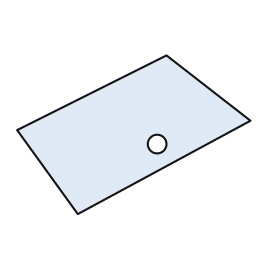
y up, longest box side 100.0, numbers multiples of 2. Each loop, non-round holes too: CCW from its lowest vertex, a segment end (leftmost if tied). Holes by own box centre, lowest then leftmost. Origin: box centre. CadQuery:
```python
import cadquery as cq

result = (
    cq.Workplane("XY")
    .moveTo(-24.0, -34.0)
    .lineTo(50.0, 6.0)
    .lineTo(14.0, 34.0)
    .lineTo(-50.0, 2.0)
    .close()
    .moveTo(10.0, -4.0)
    .circle(4.0)
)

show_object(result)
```